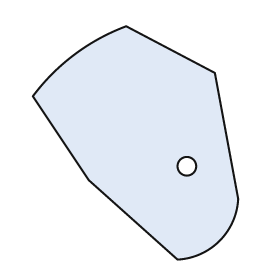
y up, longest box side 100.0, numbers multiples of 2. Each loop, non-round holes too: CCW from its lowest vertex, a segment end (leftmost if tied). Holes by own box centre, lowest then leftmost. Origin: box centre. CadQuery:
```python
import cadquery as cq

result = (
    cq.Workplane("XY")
    .moveTo(18.0, -50.0)
    .threePointArc((36.0, -42.0), (44.0, -24.0))
    .lineTo(34.0, 30.0)
    .lineTo(-4.0, 50.0)
    .threePointArc((-26.0, 38.0), (-44.0, 20.0))
    .lineTo(-20.0, -16.0)
    .close()
    .moveTo(22.0, -10.0)
    .circle(4.0)
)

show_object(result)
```